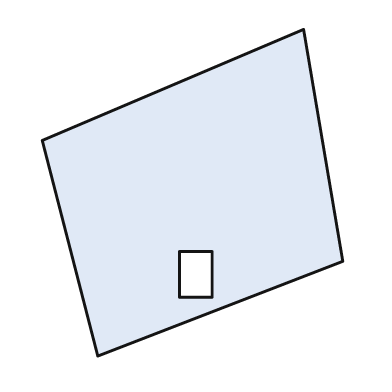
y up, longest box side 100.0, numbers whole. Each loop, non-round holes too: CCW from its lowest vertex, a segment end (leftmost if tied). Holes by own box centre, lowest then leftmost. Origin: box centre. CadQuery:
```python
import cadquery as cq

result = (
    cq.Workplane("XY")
    .moveTo(-29.0, -50.0)
    .lineTo(46.0, -21.0)
    .lineTo(34.0, 50.0)
    .lineTo(-46.0, 16.0)
    .close()
    .moveTo(-4.0, -32.0)
    .lineTo(6.0, -32.0)
    .lineTo(6.0, -18.0)
    .lineTo(-4.0, -18.0)
    .close()
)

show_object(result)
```